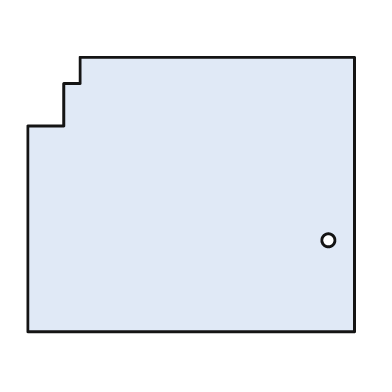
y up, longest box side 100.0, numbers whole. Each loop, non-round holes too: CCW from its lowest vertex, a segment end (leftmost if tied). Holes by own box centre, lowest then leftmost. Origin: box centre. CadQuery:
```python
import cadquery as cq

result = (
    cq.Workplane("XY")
    .moveTo(-50.0, -42.0)
    .lineTo(50.0, -42.0)
    .lineTo(50.0, 42.0)
    .lineTo(-34.0, 42.0)
    .lineTo(-34.0, 34.0)
    .lineTo(-39.0, 34.0)
    .lineTo(-39.0, 21.0)
    .lineTo(-50.0, 21.0)
    .close()
    .moveTo(42.0, -14.0)
    .circle(2.0)
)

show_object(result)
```